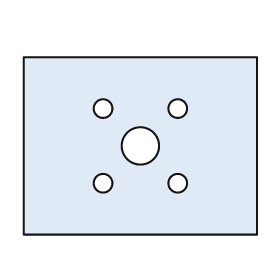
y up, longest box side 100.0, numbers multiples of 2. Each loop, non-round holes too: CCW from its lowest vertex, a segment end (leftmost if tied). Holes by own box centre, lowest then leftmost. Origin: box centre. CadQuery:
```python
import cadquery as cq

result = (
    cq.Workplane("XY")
    .moveTo(-50.0, -38.0)
    .lineTo(50.0, -38.0)
    .lineTo(50.0, 38.0)
    .lineTo(-50.0, 38.0)
    .close()
    .moveTo(-16.0, -16.0)
    .circle(4.0)
    .moveTo(16.0, -16.0)
    .circle(4.0)
    .moveTo(0.0, 0.0)
    .circle(8.0)
    .moveTo(-16.0, 16.0)
    .circle(4.0)
    .moveTo(16.0, 16.0)
    .circle(4.0)
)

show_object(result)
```